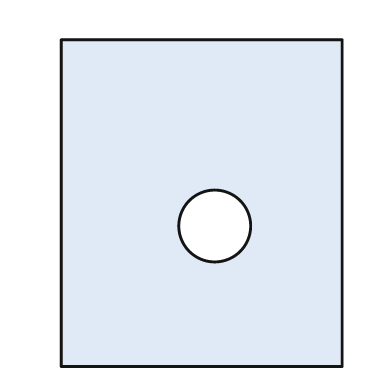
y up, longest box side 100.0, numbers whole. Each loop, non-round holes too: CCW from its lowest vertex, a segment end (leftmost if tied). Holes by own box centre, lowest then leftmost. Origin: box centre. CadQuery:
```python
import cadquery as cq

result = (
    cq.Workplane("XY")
    .moveTo(-43.0, -50.0)
    .lineTo(43.0, -50.0)
    .lineTo(43.0, 50.0)
    .lineTo(-43.0, 50.0)
    .close()
    .moveTo(4.0, -7.0)
    .circle(11.0)
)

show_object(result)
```